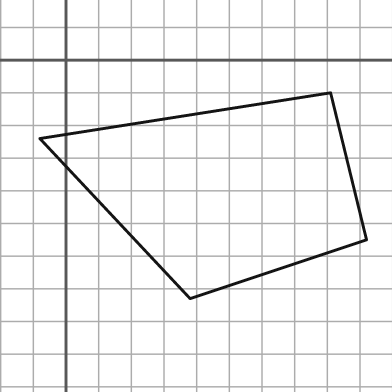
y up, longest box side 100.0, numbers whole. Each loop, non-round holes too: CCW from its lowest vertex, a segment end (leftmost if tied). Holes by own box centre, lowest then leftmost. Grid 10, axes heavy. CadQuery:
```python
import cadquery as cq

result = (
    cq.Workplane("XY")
    .moveTo(38.0, -73.0)
    .lineTo(92.0, -55.0)
    .lineTo(81.0, -10.0)
    .lineTo(-8.0, -24.0)
    .close()
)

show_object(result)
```